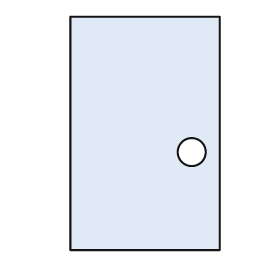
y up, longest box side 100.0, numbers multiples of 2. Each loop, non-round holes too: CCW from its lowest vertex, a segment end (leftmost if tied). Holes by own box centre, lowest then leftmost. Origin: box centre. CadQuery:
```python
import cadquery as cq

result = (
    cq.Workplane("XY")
    .moveTo(-32.0, -50.0)
    .lineTo(32.0, -50.0)
    .lineTo(32.0, 50.0)
    .lineTo(-32.0, 50.0)
    .close()
    .moveTo(20.0, -8.0)
    .circle(6.0)
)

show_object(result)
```